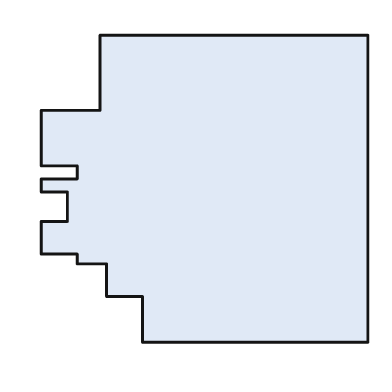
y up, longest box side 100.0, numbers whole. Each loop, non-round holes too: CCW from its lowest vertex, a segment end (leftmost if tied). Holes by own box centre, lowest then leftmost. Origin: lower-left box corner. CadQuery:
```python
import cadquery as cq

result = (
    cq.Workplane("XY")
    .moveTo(31.0, 0.0)
    .lineTo(100.0, 0.0)
    .lineTo(100.0, 94.0)
    .lineTo(18.0, 94.0)
    .lineTo(18.0, 71.0)
    .lineTo(0.0, 71.0)
    .lineTo(0.0, 54.0)
    .lineTo(11.0, 54.0)
    .lineTo(11.0, 50.0)
    .lineTo(0.0, 50.0)
    .lineTo(0.0, 46.0)
    .lineTo(8.0, 46.0)
    .lineTo(8.0, 37.0)
    .lineTo(0.0, 37.0)
    .lineTo(0.0, 27.0)
    .lineTo(11.0, 27.0)
    .lineTo(11.0, 24.0)
    .lineTo(20.0, 24.0)
    .lineTo(20.0, 14.0)
    .lineTo(31.0, 14.0)
    .close()
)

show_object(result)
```